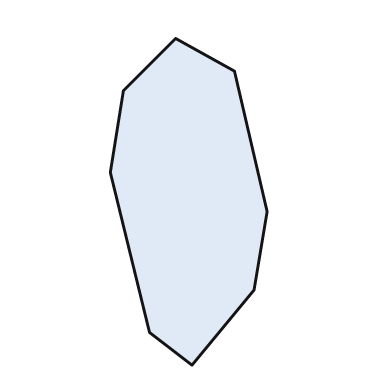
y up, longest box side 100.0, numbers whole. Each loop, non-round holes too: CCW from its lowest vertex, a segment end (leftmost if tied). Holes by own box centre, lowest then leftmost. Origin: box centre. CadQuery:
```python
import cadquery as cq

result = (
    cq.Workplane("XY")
    .moveTo(1.0, -50.0)
    .lineTo(20.0, -27.0)
    .lineTo(24.0, -3.0)
    .lineTo(14.0, 40.0)
    .lineTo(-4.0, 50.0)
    .lineTo(-20.0, 34.0)
    .lineTo(-24.0, 9.0)
    .lineTo(-12.0, -40.0)
    .close()
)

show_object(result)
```